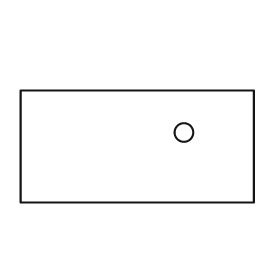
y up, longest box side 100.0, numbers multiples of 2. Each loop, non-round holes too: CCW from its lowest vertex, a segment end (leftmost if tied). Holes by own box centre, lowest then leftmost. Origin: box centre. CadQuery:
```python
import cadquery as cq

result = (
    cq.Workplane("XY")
    .moveTo(-50.0, -24.0)
    .lineTo(50.0, -24.0)
    .lineTo(50.0, 24.0)
    .lineTo(-50.0, 24.0)
    .close()
    .moveTo(20.0, 6.0)
    .circle(4.0)
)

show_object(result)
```